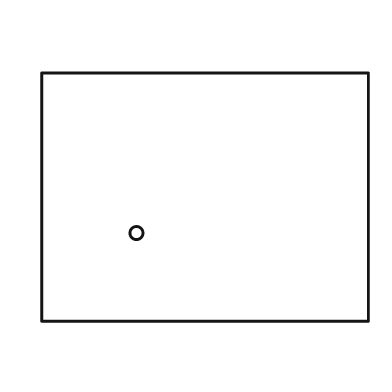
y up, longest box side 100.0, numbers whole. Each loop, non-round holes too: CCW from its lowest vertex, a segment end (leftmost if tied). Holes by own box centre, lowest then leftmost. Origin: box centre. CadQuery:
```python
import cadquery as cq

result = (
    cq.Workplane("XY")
    .moveTo(-50.0, -38.0)
    .lineTo(50.0, -38.0)
    .lineTo(50.0, 38.0)
    .lineTo(-50.0, 38.0)
    .close()
    .moveTo(-21.0, -11.0)
    .circle(2.0)
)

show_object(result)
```